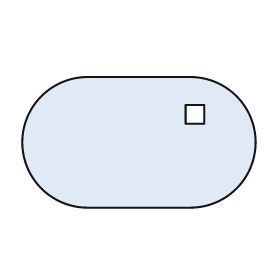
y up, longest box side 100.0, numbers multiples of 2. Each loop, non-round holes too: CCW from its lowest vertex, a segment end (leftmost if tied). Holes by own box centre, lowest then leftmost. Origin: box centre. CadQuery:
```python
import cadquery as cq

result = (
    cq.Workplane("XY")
    .moveTo(-22.0, -28.0)
    .lineTo(22.0, -28.0)
    .threePointArc((50.0, 0.0), (22.0, 28.0))
    .lineTo(-22.0, 28.0)
    .threePointArc((-50.0, 0.0), (-22.0, -28.0))
    .close()
    .moveTo(20.0, 8.0)
    .lineTo(28.0, 8.0)
    .lineTo(28.0, 16.0)
    .lineTo(20.0, 16.0)
    .close()
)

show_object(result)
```